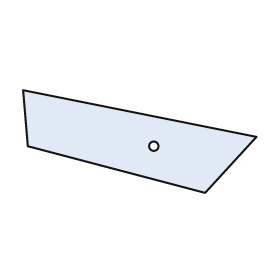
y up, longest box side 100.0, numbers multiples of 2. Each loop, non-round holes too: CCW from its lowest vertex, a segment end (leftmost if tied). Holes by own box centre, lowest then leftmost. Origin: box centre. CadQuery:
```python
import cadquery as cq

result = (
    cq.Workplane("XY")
    .moveTo(28.0, -22.0)
    .lineTo(50.0, 2.0)
    .lineTo(-50.0, 22.0)
    .lineTo(-48.0, -2.0)
    .close()
    .moveTo(6.0, -2.0)
    .circle(2.0)
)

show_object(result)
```